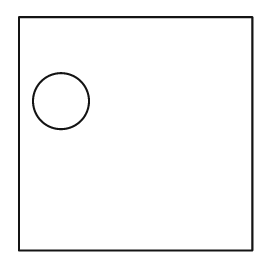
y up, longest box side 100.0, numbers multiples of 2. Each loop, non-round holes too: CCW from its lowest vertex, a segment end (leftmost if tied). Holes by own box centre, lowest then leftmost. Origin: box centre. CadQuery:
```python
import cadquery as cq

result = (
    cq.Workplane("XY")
    .moveTo(-50.0, -50.0)
    .lineTo(50.0, -50.0)
    .lineTo(50.0, 50.0)
    .lineTo(-50.0, 50.0)
    .close()
    .moveTo(-32.0, 14.0)
    .circle(12.0)
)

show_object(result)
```